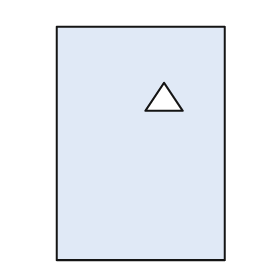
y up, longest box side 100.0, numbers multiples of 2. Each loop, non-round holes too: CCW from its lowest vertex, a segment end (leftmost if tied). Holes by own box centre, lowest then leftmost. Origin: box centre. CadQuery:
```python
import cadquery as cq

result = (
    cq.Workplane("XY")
    .moveTo(-36.0, -50.0)
    .lineTo(36.0, -50.0)
    .lineTo(36.0, 50.0)
    .lineTo(-36.0, 50.0)
    .close()
    .moveTo(2.0, 14.0)
    .lineTo(18.0, 14.0)
    .lineTo(10.0, 26.0)
    .close()
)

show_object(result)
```